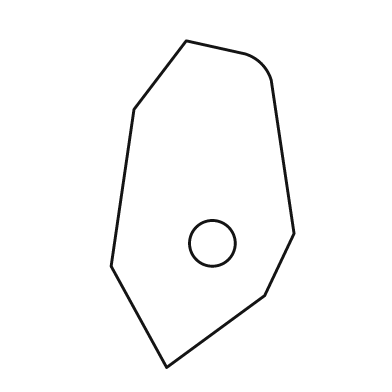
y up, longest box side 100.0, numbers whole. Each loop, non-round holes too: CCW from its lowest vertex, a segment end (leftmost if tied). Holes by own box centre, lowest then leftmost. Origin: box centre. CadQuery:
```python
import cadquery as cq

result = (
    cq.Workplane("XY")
    .moveTo(-11.0, -50.0)
    .lineTo(19.0, -28.0)
    .lineTo(28.0, -9.0)
    .lineTo(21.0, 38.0)
    .threePointArc((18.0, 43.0), (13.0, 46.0))
    .lineTo(-5.0, 50.0)
    .lineTo(-21.0, 29.0)
    .lineTo(-28.0, -19.0)
    .close()
    .moveTo(3.0, -12.0)
    .circle(7.0)
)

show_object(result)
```